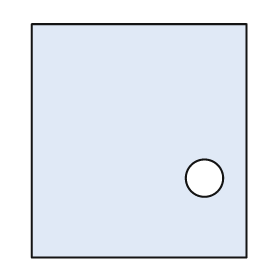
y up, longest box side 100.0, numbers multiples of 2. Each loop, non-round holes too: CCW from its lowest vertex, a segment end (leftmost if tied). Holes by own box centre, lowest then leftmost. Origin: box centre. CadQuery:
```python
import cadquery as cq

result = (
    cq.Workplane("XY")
    .moveTo(-46.0, -50.0)
    .lineTo(46.0, -50.0)
    .lineTo(46.0, 50.0)
    .lineTo(-46.0, 50.0)
    .close()
    .moveTo(28.0, -16.0)
    .circle(8.0)
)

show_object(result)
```